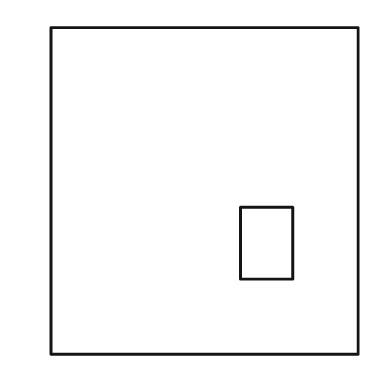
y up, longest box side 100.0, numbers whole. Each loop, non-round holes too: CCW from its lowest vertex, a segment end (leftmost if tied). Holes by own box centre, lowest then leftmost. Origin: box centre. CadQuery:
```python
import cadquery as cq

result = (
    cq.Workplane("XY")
    .moveTo(-47.0, -50.0)
    .lineTo(47.0, -50.0)
    .lineTo(47.0, 50.0)
    .lineTo(-47.0, 50.0)
    .close()
    .moveTo(11.0, -27.0)
    .lineTo(27.0, -27.0)
    .lineTo(27.0, -5.0)
    .lineTo(11.0, -5.0)
    .close()
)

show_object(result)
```